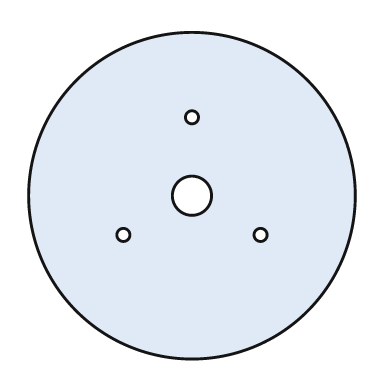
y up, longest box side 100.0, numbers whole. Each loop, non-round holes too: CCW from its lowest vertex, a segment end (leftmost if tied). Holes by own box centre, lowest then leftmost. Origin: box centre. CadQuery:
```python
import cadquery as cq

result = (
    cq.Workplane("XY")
    .moveTo(0.0, 0.0)
    .circle(50.0)
    .moveTo(-21.0, -12.0)
    .circle(2.0)
    .moveTo(21.0, -12.0)
    .circle(2.0)
    .moveTo(0.0, 0.0)
    .circle(6.0)
    .moveTo(0.0, 24.0)
    .circle(2.0)
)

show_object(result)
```